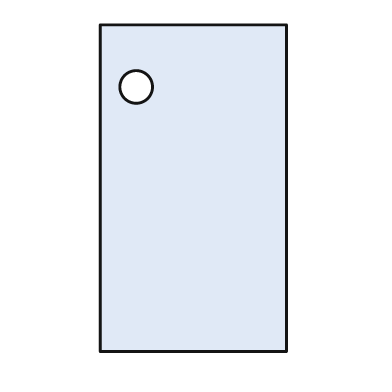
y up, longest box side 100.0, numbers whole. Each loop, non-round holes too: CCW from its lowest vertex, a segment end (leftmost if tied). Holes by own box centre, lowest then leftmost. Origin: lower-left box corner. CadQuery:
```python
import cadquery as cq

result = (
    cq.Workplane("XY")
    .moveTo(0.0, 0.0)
    .lineTo(57.0, 0.0)
    .lineTo(57.0, 100.0)
    .lineTo(0.0, 100.0)
    .close()
    .moveTo(11.0, 81.0)
    .circle(5.0)
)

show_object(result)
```